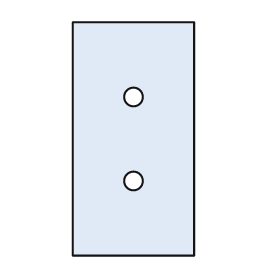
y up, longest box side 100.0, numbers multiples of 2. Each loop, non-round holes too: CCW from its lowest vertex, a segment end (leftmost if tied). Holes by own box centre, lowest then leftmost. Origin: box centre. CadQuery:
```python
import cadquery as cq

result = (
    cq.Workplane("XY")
    .moveTo(-26.0, -50.0)
    .lineTo(26.0, -50.0)
    .lineTo(26.0, 50.0)
    .lineTo(-26.0, 50.0)
    .close()
    .moveTo(0.0, -18.0)
    .circle(4.0)
    .moveTo(0.0, 18.0)
    .circle(4.0)
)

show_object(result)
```